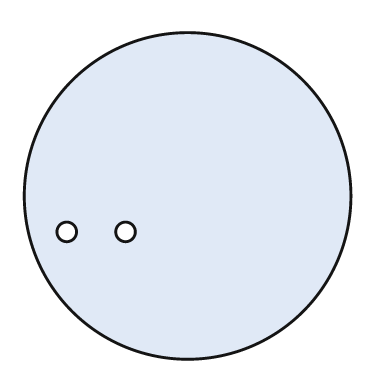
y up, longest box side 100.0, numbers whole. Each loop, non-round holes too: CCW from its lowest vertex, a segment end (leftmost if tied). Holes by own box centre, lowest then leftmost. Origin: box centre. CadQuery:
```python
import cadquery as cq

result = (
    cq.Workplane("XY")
    .moveTo(0.0, 0.0)
    .circle(50.0)
    .moveTo(-37.0, -11.0)
    .circle(3.0)
    .moveTo(-19.0, -11.0)
    .circle(3.0)
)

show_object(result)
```